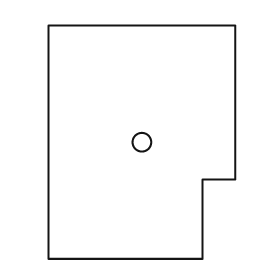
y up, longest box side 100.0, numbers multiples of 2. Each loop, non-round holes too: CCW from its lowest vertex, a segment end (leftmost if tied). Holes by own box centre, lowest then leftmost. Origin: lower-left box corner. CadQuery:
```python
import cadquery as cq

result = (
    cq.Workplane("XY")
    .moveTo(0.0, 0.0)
    .lineTo(66.0, 0.0)
    .lineTo(66.0, 34.0)
    .lineTo(80.0, 34.0)
    .lineTo(80.0, 100.0)
    .lineTo(0.0, 100.0)
    .close()
    .moveTo(40.0, 50.0)
    .circle(4.0)
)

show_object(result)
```